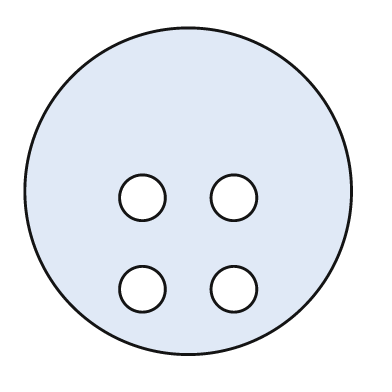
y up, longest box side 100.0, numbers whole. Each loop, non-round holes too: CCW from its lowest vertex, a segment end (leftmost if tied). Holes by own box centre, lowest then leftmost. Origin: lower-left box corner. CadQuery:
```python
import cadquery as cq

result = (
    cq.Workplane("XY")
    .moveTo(50.0, 50.0)
    .circle(50.0)
    .moveTo(36.0, 20.0)
    .circle(7.0)
    .moveTo(64.0, 20.0)
    .circle(7.0)
    .moveTo(36.0, 48.0)
    .circle(7.0)
    .moveTo(64.0, 48.0)
    .circle(7.0)
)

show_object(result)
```